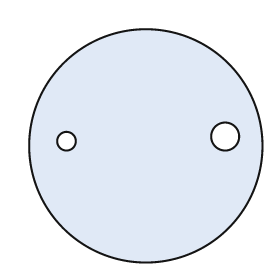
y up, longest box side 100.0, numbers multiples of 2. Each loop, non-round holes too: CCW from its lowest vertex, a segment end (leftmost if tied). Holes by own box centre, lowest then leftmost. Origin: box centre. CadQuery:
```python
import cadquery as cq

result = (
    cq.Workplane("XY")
    .moveTo(0.0, 0.0)
    .circle(50.0)
    .moveTo(-34.0, 2.0)
    .circle(4.0)
    .moveTo(34.0, 4.0)
    .circle(6.0)
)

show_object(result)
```